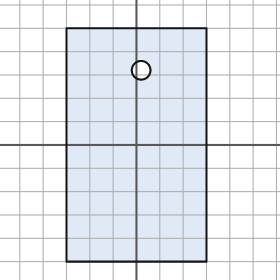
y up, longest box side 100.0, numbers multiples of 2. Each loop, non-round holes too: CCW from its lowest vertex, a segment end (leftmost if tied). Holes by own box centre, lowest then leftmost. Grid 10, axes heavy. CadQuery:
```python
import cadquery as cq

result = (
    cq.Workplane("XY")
    .moveTo(-30.0, -50.0)
    .lineTo(30.0, -50.0)
    .lineTo(30.0, 50.0)
    .lineTo(-30.0, 50.0)
    .close()
    .moveTo(2.0, 32.0)
    .circle(4.0)
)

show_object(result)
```